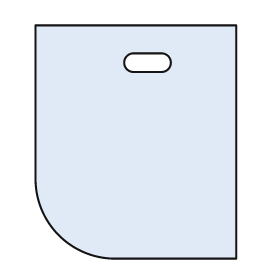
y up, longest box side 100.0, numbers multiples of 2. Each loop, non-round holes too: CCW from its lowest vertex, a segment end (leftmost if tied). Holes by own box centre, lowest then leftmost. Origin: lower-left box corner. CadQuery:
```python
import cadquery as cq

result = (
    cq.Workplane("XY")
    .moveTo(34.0, 0.0)
    .lineTo(86.0, 0.0)
    .lineTo(86.0, 100.0)
    .lineTo(0.0, 100.0)
    .lineTo(0.0, 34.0)
    .threePointArc((10.0, 10.0), (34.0, 0.0))
    .close()
    .moveTo(42.0, 80.0)
    .lineTo(54.0, 80.0)
    .threePointArc((58.0, 84.0), (54.0, 88.0))
    .lineTo(42.0, 88.0)
    .threePointArc((38.0, 84.0), (42.0, 80.0))
    .close()
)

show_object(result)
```